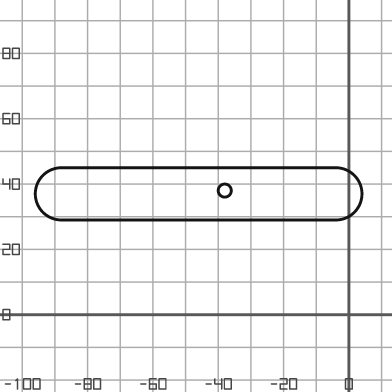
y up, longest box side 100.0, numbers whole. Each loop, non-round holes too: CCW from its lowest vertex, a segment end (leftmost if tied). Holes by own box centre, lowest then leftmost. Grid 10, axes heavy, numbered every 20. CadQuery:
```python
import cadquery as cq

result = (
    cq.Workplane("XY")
    .moveTo(-88.0, 29.0)
    .lineTo(-4.0, 29.0)
    .threePointArc((4.0, 37.0), (-4.0, 45.0))
    .lineTo(-88.0, 45.0)
    .threePointArc((-96.0, 37.0), (-88.0, 29.0))
    .close()
    .moveTo(-38.0, 38.0)
    .circle(2.0)
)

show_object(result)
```